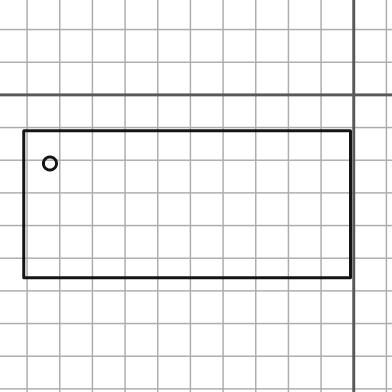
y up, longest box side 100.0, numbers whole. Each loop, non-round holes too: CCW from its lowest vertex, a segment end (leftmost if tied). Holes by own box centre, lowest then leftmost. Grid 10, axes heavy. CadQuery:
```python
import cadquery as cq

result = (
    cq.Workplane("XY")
    .moveTo(-101.0, -56.0)
    .lineTo(-1.0, -56.0)
    .lineTo(-1.0, -11.0)
    .lineTo(-101.0, -11.0)
    .close()
    .moveTo(-93.0, -21.0)
    .circle(2.0)
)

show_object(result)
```